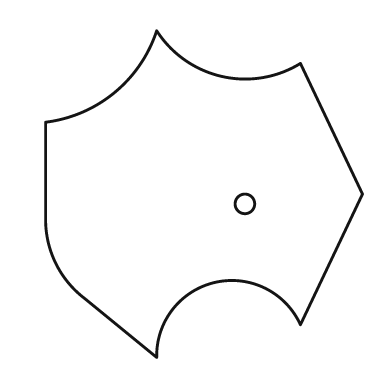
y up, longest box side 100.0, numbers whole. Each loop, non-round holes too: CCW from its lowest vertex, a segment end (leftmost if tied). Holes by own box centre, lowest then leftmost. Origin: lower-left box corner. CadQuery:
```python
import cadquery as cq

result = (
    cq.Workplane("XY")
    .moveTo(34.0, 0.0)
    .threePointArc((52.0, 23.0), (78.0, 10.0))
    .lineTo(97.0, 50.0)
    .lineTo(78.0, 90.0)
    .threePointArc((54.0, 86.0), (34.0, 100.0))
    .threePointArc((21.0, 81.0), (0.0, 72.0))
    .lineTo(0.0, 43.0)
    .threePointArc((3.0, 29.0), (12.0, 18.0))
    .close()
    .moveTo(61.0, 47.0)
    .circle(3.0)
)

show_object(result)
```